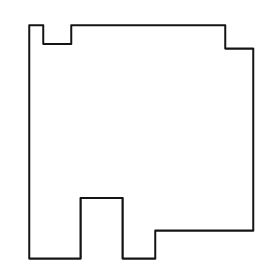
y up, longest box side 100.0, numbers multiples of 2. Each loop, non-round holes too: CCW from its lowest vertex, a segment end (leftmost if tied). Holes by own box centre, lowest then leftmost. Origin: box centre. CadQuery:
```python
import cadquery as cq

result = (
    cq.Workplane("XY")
    .moveTo(-48.0, -50.0)
    .lineTo(-26.0, -50.0)
    .lineTo(-26.0, -24.0)
    .lineTo(-8.0, -24.0)
    .lineTo(-8.0, -50.0)
    .lineTo(6.0, -50.0)
    .lineTo(6.0, -38.0)
    .lineTo(48.0, -38.0)
    .lineTo(48.0, 40.0)
    .lineTo(36.0, 40.0)
    .lineTo(36.0, 50.0)
    .lineTo(-30.0, 50.0)
    .lineTo(-30.0, 42.0)
    .lineTo(-42.0, 42.0)
    .lineTo(-42.0, 50.0)
    .lineTo(-48.0, 50.0)
    .close()
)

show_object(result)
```